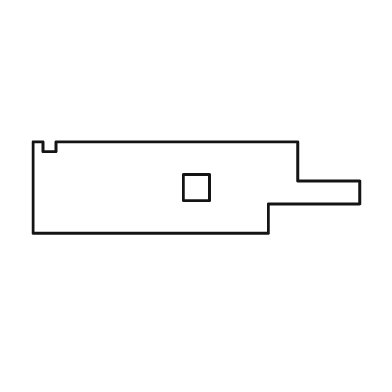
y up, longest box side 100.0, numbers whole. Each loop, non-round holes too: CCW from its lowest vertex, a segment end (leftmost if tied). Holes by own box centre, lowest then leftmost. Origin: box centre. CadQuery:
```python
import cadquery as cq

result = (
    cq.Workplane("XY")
    .moveTo(-50.0, -14.0)
    .lineTo(22.0, -14.0)
    .lineTo(22.0, -5.0)
    .lineTo(50.0, -5.0)
    .lineTo(50.0, 2.0)
    .lineTo(31.0, 2.0)
    .lineTo(31.0, 14.0)
    .lineTo(-43.0, 14.0)
    .lineTo(-43.0, 11.0)
    .lineTo(-47.0, 11.0)
    .lineTo(-47.0, 14.0)
    .lineTo(-50.0, 14.0)
    .close()
    .moveTo(-4.0, -4.0)
    .lineTo(4.0, -4.0)
    .lineTo(4.0, 4.0)
    .lineTo(-4.0, 4.0)
    .close()
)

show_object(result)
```